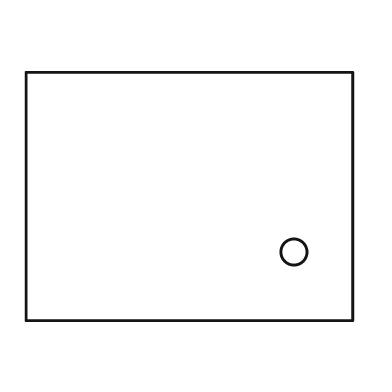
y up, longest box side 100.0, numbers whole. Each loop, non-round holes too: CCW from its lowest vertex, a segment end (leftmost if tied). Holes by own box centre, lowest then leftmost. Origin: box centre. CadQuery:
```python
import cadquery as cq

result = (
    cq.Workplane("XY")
    .moveTo(-50.0, -38.0)
    .lineTo(50.0, -38.0)
    .lineTo(50.0, 38.0)
    .lineTo(-50.0, 38.0)
    .close()
    .moveTo(32.0, -17.0)
    .circle(4.0)
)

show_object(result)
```